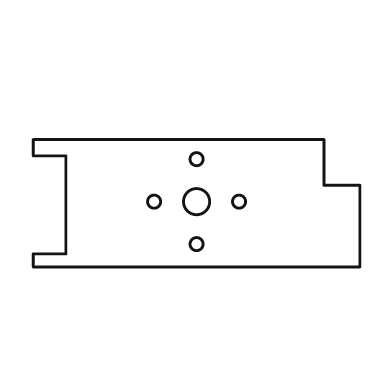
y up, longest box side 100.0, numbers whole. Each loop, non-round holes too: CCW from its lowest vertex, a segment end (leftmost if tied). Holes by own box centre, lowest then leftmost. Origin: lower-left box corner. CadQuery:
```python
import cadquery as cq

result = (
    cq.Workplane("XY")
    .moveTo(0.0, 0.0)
    .lineTo(100.0, 0.0)
    .lineTo(100.0, 25.0)
    .lineTo(89.0, 25.0)
    .lineTo(89.0, 39.0)
    .lineTo(0.0, 39.0)
    .lineTo(0.0, 34.0)
    .lineTo(10.0, 34.0)
    .lineTo(10.0, 4.0)
    .lineTo(0.0, 4.0)
    .close()
    .moveTo(50.0, 7.0)
    .circle(2.0)
    .moveTo(37.0, 20.0)
    .circle(2.0)
    .moveTo(50.0, 20.0)
    .circle(4.0)
    .moveTo(63.0, 20.0)
    .circle(2.0)
    .moveTo(50.0, 33.0)
    .circle(2.0)
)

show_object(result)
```